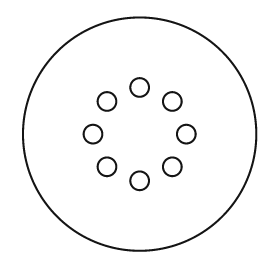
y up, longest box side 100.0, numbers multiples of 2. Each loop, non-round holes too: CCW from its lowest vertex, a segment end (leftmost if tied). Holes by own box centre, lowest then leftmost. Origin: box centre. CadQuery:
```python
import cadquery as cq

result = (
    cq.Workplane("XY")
    .moveTo(0.0, 0.0)
    .circle(50.0)
    .moveTo(0.0, -20.0)
    .circle(4.0)
    .moveTo(-14.0, -14.0)
    .circle(4.0)
    .moveTo(14.0, -14.0)
    .circle(4.0)
    .moveTo(-20.0, 0.0)
    .circle(4.0)
    .moveTo(20.0, 0.0)
    .circle(4.0)
    .moveTo(-14.0, 14.0)
    .circle(4.0)
    .moveTo(14.0, 14.0)
    .circle(4.0)
    .moveTo(0.0, 20.0)
    .circle(4.0)
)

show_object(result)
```